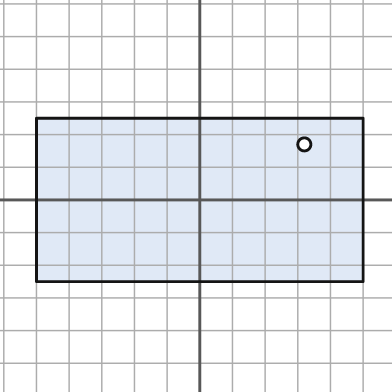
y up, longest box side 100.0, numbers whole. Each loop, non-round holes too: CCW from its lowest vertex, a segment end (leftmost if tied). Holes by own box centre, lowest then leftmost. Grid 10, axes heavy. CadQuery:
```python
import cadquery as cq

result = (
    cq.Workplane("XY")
    .moveTo(-50.0, -25.0)
    .lineTo(50.0, -25.0)
    .lineTo(50.0, 25.0)
    .lineTo(-50.0, 25.0)
    .close()
    .moveTo(32.0, 17.0)
    .circle(2.0)
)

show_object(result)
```